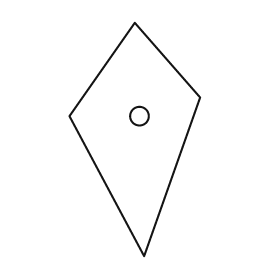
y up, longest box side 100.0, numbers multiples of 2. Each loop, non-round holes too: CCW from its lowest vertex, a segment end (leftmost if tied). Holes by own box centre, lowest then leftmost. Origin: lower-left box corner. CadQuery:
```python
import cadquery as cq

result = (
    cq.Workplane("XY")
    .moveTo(32.0, 0.0)
    .lineTo(56.0, 68.0)
    .lineTo(28.0, 100.0)
    .lineTo(0.0, 60.0)
    .close()
    .moveTo(30.0, 60.0)
    .circle(4.0)
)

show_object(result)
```